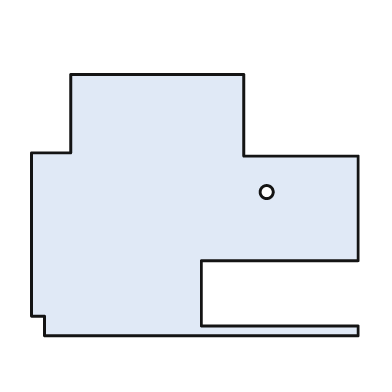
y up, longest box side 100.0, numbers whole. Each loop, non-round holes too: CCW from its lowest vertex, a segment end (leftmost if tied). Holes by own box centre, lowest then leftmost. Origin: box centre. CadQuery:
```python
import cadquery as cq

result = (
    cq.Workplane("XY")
    .moveTo(-46.0, -40.0)
    .lineTo(50.0, -40.0)
    .lineTo(50.0, -37.0)
    .lineTo(2.0, -37.0)
    .lineTo(2.0, -17.0)
    .lineTo(50.0, -17.0)
    .lineTo(50.0, 15.0)
    .lineTo(15.0, 15.0)
    .lineTo(15.0, 40.0)
    .lineTo(-38.0, 40.0)
    .lineTo(-38.0, 16.0)
    .lineTo(-50.0, 16.0)
    .lineTo(-50.0, -34.0)
    .lineTo(-46.0, -34.0)
    .close()
    .moveTo(22.0, 4.0)
    .circle(2.0)
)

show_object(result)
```